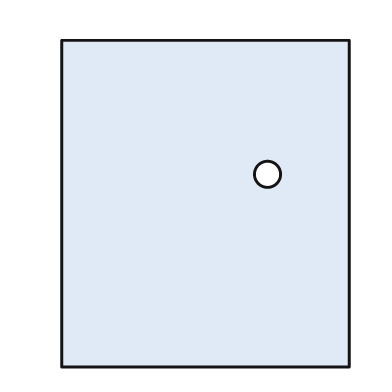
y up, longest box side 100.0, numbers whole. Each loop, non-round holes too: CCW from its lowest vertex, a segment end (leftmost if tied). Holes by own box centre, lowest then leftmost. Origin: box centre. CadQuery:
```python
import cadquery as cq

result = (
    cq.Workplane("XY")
    .moveTo(-44.0, -50.0)
    .lineTo(44.0, -50.0)
    .lineTo(44.0, 50.0)
    .lineTo(-44.0, 50.0)
    .close()
    .moveTo(19.0, 9.0)
    .circle(4.0)
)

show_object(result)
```